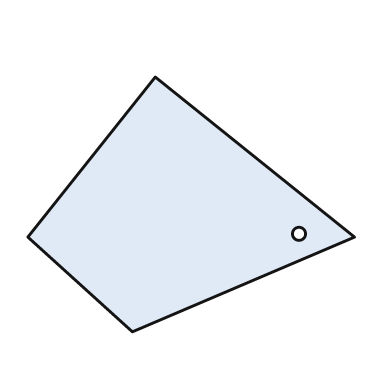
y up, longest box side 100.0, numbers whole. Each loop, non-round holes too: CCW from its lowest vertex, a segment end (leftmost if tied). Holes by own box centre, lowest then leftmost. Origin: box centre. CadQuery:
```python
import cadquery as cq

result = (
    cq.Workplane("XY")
    .moveTo(-18.0, -39.0)
    .lineTo(50.0, -10.0)
    .lineTo(-11.0, 39.0)
    .lineTo(-50.0, -10.0)
    .close()
    .moveTo(33.0, -9.0)
    .circle(2.0)
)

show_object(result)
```